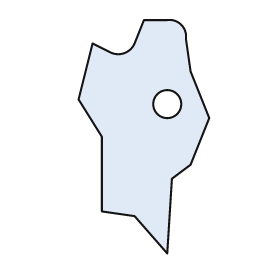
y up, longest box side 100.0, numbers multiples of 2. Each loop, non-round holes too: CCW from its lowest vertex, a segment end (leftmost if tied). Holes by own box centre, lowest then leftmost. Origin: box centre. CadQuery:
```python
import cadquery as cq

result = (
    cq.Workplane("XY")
    .moveTo(10.0, -50.0)
    .lineTo(12.0, -18.0)
    .lineTo(20.0, -12.0)
    .lineTo(28.0, 8.0)
    .lineTo(20.0, 28.0)
    .lineTo(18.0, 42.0)
    .threePointArc((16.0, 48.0), (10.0, 50.0))
    .lineTo(0.0, 50.0)
    .lineTo(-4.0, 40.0)
    .threePointArc((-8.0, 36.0), (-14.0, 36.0))
    .lineTo(-22.0, 40.0)
    .lineTo(-28.0, 16.0)
    .lineTo(-18.0, 0.0)
    .lineTo(-18.0, -32.0)
    .lineTo(-4.0, -34.0)
    .close()
    .moveTo(10.0, 14.0)
    .circle(6.0)
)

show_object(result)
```